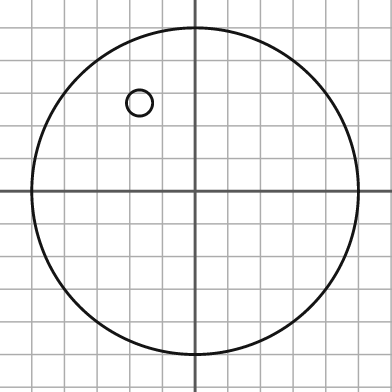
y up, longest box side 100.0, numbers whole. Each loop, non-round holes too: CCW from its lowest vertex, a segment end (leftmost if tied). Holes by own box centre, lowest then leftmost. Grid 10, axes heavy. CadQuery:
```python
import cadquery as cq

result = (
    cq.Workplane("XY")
    .moveTo(0.0, 0.0)
    .circle(50.0)
    .moveTo(-17.0, 27.0)
    .circle(4.0)
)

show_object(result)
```